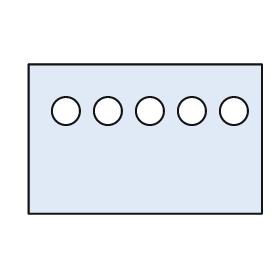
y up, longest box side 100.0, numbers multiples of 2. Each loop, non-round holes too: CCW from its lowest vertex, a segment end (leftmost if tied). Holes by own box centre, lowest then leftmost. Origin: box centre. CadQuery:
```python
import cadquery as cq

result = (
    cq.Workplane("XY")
    .moveTo(-50.0, -32.0)
    .lineTo(50.0, -32.0)
    .lineTo(50.0, 32.0)
    .lineTo(-50.0, 32.0)
    .close()
    .moveTo(-34.0, 12.0)
    .circle(6.0)
    .moveTo(-16.0, 12.0)
    .circle(6.0)
    .moveTo(2.0, 12.0)
    .circle(6.0)
    .moveTo(20.0, 12.0)
    .circle(6.0)
    .moveTo(38.0, 12.0)
    .circle(6.0)
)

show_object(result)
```